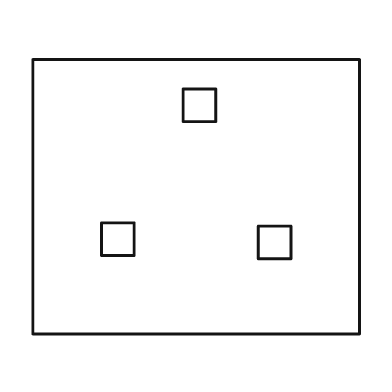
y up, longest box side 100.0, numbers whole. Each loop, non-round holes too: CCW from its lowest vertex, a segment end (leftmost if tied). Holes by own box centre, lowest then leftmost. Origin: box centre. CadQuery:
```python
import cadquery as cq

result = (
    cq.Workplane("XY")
    .moveTo(-50.0, -42.0)
    .lineTo(50.0, -42.0)
    .lineTo(50.0, 42.0)
    .lineTo(-50.0, 42.0)
    .close()
    .moveTo(19.0, -19.0)
    .lineTo(29.0, -19.0)
    .lineTo(29.0, -9.0)
    .lineTo(19.0, -9.0)
    .close()
    .moveTo(-29.0, -18.0)
    .lineTo(-19.0, -18.0)
    .lineTo(-19.0, -8.0)
    .lineTo(-29.0, -8.0)
    .close()
    .moveTo(-4.0, 23.0)
    .lineTo(6.0, 23.0)
    .lineTo(6.0, 33.0)
    .lineTo(-4.0, 33.0)
    .close()
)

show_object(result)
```